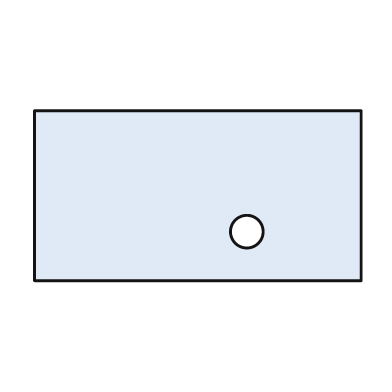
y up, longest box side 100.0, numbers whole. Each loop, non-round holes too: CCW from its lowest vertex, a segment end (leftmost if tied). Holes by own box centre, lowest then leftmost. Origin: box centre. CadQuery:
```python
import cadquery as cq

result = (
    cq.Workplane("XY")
    .moveTo(-50.0, -26.0)
    .lineTo(50.0, -26.0)
    .lineTo(50.0, 26.0)
    .lineTo(-50.0, 26.0)
    .close()
    .moveTo(15.0, -11.0)
    .circle(5.0)
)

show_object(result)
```